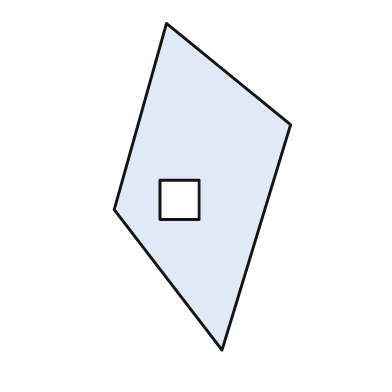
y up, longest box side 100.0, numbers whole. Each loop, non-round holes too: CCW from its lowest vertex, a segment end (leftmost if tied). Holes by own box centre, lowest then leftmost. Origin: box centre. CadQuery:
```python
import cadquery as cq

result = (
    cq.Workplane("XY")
    .moveTo(6.0, -50.0)
    .lineTo(27.0, 19.0)
    .lineTo(-11.0, 50.0)
    .lineTo(-27.0, -7.0)
    .close()
    .moveTo(-13.0, -10.0)
    .lineTo(-1.0, -10.0)
    .lineTo(-1.0, 2.0)
    .lineTo(-13.0, 2.0)
    .close()
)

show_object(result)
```